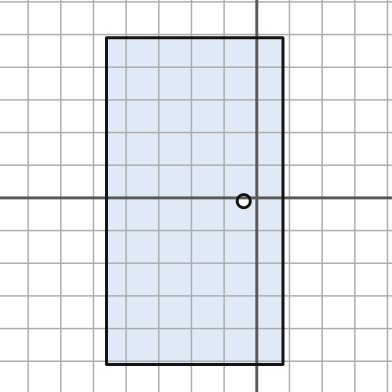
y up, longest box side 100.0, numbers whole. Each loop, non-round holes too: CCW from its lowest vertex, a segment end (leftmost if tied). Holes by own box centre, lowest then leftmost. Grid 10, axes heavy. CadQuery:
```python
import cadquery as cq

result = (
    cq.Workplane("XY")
    .moveTo(-46.0, -51.0)
    .lineTo(8.0, -51.0)
    .lineTo(8.0, 49.0)
    .lineTo(-46.0, 49.0)
    .close()
    .moveTo(-4.0, -1.0)
    .circle(2.0)
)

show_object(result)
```